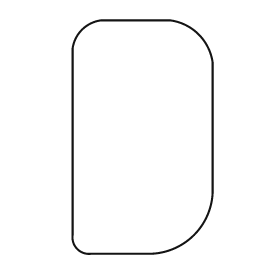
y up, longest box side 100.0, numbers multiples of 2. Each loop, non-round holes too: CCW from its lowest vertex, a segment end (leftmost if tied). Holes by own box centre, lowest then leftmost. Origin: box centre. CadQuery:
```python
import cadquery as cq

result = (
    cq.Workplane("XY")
    .moveTo(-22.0, -50.0)
    .lineTo(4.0, -50.0)
    .threePointArc((22.0, -42.0), (30.0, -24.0))
    .lineTo(30.0, 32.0)
    .threePointArc((24.0, 44.0), (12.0, 50.0))
    .lineTo(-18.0, 50.0)
    .threePointArc((-26.0, 46.0), (-30.0, 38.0))
    .lineTo(-30.0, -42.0)
    .threePointArc((-28.0, -48.0), (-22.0, -50.0))
    .close()
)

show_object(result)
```